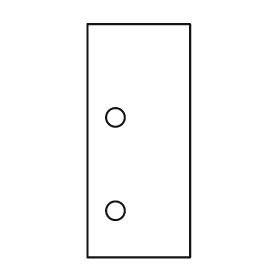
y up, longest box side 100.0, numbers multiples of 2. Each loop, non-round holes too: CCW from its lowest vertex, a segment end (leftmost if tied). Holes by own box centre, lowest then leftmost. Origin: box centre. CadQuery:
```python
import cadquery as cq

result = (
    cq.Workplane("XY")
    .moveTo(-22.0, -50.0)
    .lineTo(22.0, -50.0)
    .lineTo(22.0, 50.0)
    .lineTo(-22.0, 50.0)
    .close()
    .moveTo(-10.0, -30.0)
    .circle(4.0)
    .moveTo(-10.0, 10.0)
    .circle(4.0)
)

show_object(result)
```